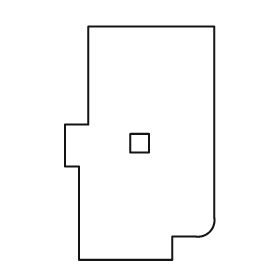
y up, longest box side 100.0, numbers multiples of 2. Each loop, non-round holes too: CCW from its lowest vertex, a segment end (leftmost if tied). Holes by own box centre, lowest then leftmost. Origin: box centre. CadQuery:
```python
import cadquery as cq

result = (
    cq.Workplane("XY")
    .moveTo(-26.0, -50.0)
    .lineTo(14.0, -50.0)
    .lineTo(14.0, -40.0)
    .lineTo(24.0, -40.0)
    .threePointArc((30.0, -38.0), (32.0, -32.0))
    .lineTo(32.0, 50.0)
    .lineTo(-22.0, 50.0)
    .lineTo(-22.0, 8.0)
    .lineTo(-32.0, 8.0)
    .lineTo(-32.0, -10.0)
    .lineTo(-26.0, -10.0)
    .close()
    .moveTo(-4.0, -4.0)
    .lineTo(4.0, -4.0)
    .lineTo(4.0, 4.0)
    .lineTo(-4.0, 4.0)
    .close()
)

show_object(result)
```